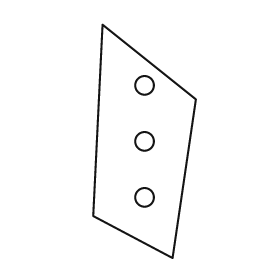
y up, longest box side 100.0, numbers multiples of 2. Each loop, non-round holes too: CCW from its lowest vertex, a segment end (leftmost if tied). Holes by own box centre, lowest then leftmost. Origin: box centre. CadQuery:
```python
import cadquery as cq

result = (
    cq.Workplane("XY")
    .moveTo(12.0, -50.0)
    .lineTo(22.0, 18.0)
    .lineTo(-18.0, 50.0)
    .lineTo(-22.0, -32.0)
    .close()
    .moveTo(0.0, -24.0)
    .circle(4.0)
    .moveTo(0.0, 0.0)
    .circle(4.0)
    .moveTo(0.0, 24.0)
    .circle(4.0)
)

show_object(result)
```